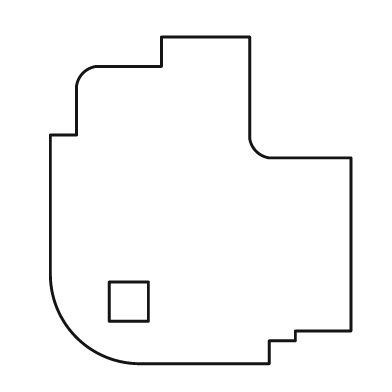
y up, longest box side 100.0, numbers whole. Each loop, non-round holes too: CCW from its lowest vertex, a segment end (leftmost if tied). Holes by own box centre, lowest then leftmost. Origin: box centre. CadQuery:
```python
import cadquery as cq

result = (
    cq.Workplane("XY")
    .moveTo(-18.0, -50.0)
    .lineTo(21.0, -50.0)
    .lineTo(21.0, -43.0)
    .lineTo(29.0, -43.0)
    .lineTo(29.0, -40.0)
    .lineTo(46.0, -40.0)
    .lineTo(46.0, 13.0)
    .lineTo(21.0, 13.0)
    .threePointArc((17.0, 15.0), (15.0, 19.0))
    .lineTo(15.0, 50.0)
    .lineTo(-12.0, 50.0)
    .lineTo(-12.0, 41.0)
    .lineTo(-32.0, 41.0)
    .threePointArc((-36.0, 39.0), (-38.0, 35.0))
    .lineTo(-38.0, 20.0)
    .lineTo(-46.0, 20.0)
    .lineTo(-46.0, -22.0)
    .threePointArc((-38.0, -42.0), (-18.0, -50.0))
    .close()
    .moveTo(-28.0, -37.0)
    .lineTo(-16.0, -37.0)
    .lineTo(-16.0, -25.0)
    .lineTo(-28.0, -25.0)
    .close()
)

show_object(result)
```